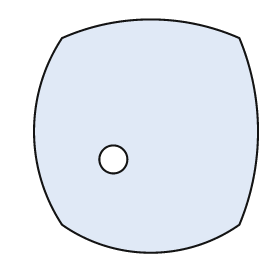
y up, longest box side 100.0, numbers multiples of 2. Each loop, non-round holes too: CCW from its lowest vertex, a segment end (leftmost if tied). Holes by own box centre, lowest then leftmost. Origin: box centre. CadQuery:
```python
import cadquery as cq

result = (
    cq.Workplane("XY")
    .moveTo(-36.0, -38.0)
    .threePointArc((2.0, -50.0), (40.0, -38.0))
    .threePointArc((48.0, 2.0), (40.0, 42.0))
    .threePointArc((2.0, 50.0), (-36.0, 42.0))
    .threePointArc((-48.0, 2.0), (-36.0, -38.0))
    .close()
    .moveTo(-14.0, -10.0)
    .circle(6.0)
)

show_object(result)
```